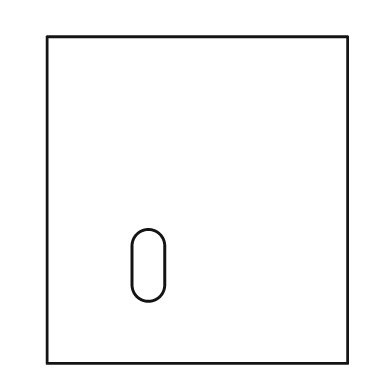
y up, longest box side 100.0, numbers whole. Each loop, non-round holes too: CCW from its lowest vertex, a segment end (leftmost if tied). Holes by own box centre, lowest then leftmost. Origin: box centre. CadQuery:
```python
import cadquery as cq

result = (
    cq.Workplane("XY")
    .moveTo(-46.0, -50.0)
    .lineTo(46.0, -50.0)
    .lineTo(46.0, 50.0)
    .lineTo(-46.0, 50.0)
    .close()
    .moveTo(-20.0, -26.0)
    .threePointArc((-15.0, -31.0), (-10.0, -26.0))
    .lineTo(-10.0, -14.0)
    .threePointArc((-15.0, -9.0), (-20.0, -14.0))
    .close()
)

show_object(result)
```